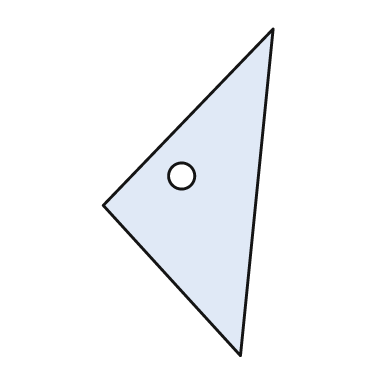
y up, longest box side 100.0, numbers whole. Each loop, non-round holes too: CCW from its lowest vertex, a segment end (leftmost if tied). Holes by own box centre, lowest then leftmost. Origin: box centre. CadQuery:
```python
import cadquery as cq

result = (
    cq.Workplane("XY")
    .moveTo(16.0, -50.0)
    .lineTo(26.0, 50.0)
    .lineTo(-26.0, -4.0)
    .close()
    .moveTo(-2.0, 5.0)
    .circle(4.0)
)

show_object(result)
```